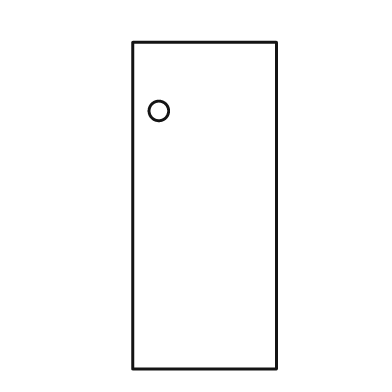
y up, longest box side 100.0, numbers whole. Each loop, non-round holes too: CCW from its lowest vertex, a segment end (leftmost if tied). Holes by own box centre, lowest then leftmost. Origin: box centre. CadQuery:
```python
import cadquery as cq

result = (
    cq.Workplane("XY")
    .moveTo(-22.0, -50.0)
    .lineTo(22.0, -50.0)
    .lineTo(22.0, 50.0)
    .lineTo(-22.0, 50.0)
    .close()
    .moveTo(-14.0, 29.0)
    .circle(3.0)
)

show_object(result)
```